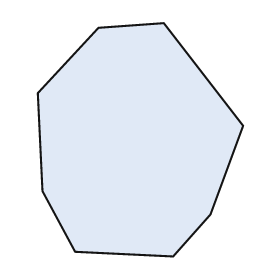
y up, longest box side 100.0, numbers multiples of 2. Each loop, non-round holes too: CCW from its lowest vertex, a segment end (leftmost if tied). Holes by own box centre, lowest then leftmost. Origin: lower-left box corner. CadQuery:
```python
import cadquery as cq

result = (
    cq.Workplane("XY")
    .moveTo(58.0, 0.0)
    .lineTo(74.0, 18.0)
    .lineTo(88.0, 56.0)
    .lineTo(54.0, 100.0)
    .lineTo(26.0, 98.0)
    .lineTo(0.0, 70.0)
    .lineTo(2.0, 28.0)
    .lineTo(16.0, 2.0)
    .close()
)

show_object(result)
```